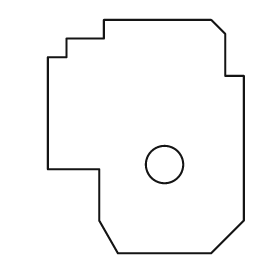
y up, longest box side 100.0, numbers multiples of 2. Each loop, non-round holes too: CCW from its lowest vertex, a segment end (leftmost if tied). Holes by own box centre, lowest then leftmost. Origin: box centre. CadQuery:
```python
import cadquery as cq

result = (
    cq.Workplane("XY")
    .moveTo(-12.0, -50.0)
    .lineTo(28.0, -50.0)
    .lineTo(42.0, -36.0)
    .lineTo(42.0, 26.0)
    .lineTo(34.0, 26.0)
    .lineTo(34.0, 44.0)
    .lineTo(28.0, 50.0)
    .lineTo(-18.0, 50.0)
    .lineTo(-18.0, 42.0)
    .lineTo(-34.0, 42.0)
    .lineTo(-34.0, 34.0)
    .lineTo(-42.0, 34.0)
    .lineTo(-42.0, -14.0)
    .lineTo(-20.0, -14.0)
    .lineTo(-20.0, -36.0)
    .close()
    .moveTo(8.0, -12.0)
    .circle(8.0)
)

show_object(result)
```